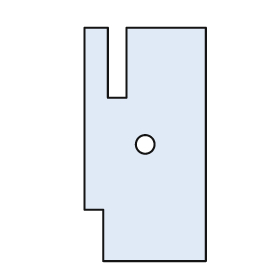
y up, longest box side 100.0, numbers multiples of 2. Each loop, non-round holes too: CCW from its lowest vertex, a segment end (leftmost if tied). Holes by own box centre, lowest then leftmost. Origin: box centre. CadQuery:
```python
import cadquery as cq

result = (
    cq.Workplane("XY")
    .moveTo(-18.0, -50.0)
    .lineTo(26.0, -50.0)
    .lineTo(26.0, 50.0)
    .lineTo(-8.0, 50.0)
    .lineTo(-8.0, 20.0)
    .lineTo(-16.0, 20.0)
    .lineTo(-16.0, 50.0)
    .lineTo(-26.0, 50.0)
    .lineTo(-26.0, -28.0)
    .lineTo(-18.0, -28.0)
    .close()
    .moveTo(0.0, 0.0)
    .circle(4.0)
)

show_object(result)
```